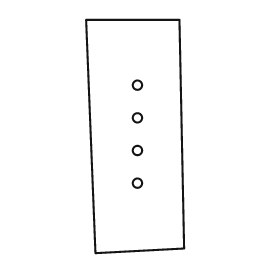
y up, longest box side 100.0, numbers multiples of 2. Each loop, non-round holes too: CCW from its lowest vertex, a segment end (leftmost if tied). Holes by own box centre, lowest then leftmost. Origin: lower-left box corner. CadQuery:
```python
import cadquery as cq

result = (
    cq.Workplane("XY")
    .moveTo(4.0, 0.0)
    .lineTo(42.0, 2.0)
    .lineTo(40.0, 100.0)
    .lineTo(0.0, 100.0)
    .close()
    .moveTo(22.0, 30.0)
    .circle(2.0)
    .moveTo(22.0, 44.0)
    .circle(2.0)
    .moveTo(22.0, 58.0)
    .circle(2.0)
    .moveTo(22.0, 72.0)
    .circle(2.0)
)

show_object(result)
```